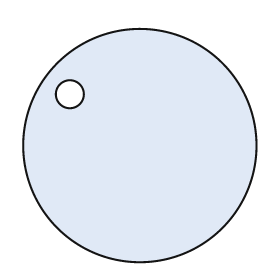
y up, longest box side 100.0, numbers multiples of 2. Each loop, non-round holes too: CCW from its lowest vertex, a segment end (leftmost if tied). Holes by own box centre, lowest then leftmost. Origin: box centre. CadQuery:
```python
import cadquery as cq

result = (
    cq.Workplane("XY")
    .moveTo(0.0, 0.0)
    .circle(50.0)
    .moveTo(-30.0, 22.0)
    .circle(6.0)
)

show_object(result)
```